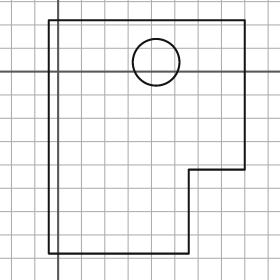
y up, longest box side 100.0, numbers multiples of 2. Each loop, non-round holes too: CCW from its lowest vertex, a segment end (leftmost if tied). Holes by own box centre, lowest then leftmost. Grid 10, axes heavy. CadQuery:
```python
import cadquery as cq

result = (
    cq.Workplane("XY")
    .moveTo(-4.0, -78.0)
    .lineTo(56.0, -78.0)
    .lineTo(56.0, -42.0)
    .lineTo(80.0, -42.0)
    .lineTo(80.0, 22.0)
    .lineTo(-4.0, 22.0)
    .close()
    .moveTo(42.0, 4.0)
    .circle(10.0)
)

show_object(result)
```